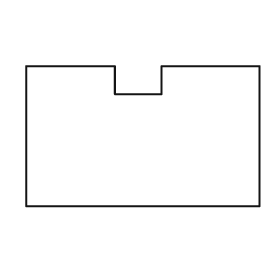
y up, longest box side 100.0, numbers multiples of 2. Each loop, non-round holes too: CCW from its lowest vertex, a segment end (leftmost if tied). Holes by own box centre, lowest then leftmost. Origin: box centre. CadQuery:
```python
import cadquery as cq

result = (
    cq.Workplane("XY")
    .moveTo(-50.0, -30.0)
    .lineTo(50.0, -30.0)
    .lineTo(50.0, 30.0)
    .lineTo(8.0, 30.0)
    .lineTo(8.0, 18.0)
    .lineTo(-12.0, 18.0)
    .lineTo(-12.0, 30.0)
    .lineTo(-50.0, 30.0)
    .close()
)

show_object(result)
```